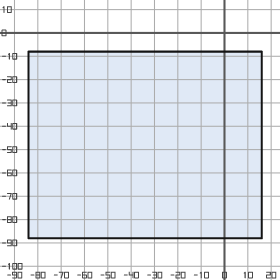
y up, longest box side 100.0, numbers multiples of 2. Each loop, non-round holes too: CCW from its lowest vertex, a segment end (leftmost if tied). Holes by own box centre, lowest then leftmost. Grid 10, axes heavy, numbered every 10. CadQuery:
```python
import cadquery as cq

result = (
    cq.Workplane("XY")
    .moveTo(-84.0, -88.0)
    .lineTo(16.0, -88.0)
    .lineTo(16.0, -8.0)
    .lineTo(-84.0, -8.0)
    .close()
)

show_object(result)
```